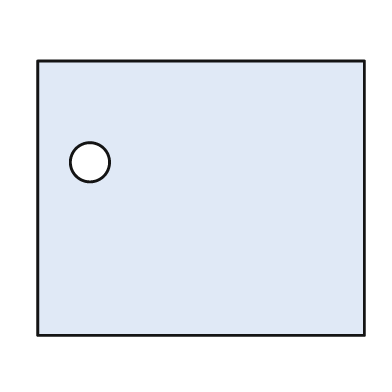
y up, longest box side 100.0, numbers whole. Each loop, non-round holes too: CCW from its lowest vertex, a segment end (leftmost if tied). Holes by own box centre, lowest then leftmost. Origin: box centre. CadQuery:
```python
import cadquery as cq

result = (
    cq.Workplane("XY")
    .moveTo(-50.0, -42.0)
    .lineTo(50.0, -42.0)
    .lineTo(50.0, 42.0)
    .lineTo(-50.0, 42.0)
    .close()
    .moveTo(-34.0, 11.0)
    .circle(6.0)
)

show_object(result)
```